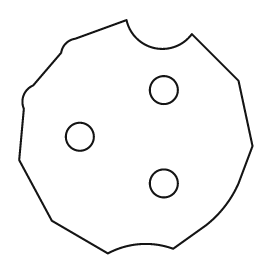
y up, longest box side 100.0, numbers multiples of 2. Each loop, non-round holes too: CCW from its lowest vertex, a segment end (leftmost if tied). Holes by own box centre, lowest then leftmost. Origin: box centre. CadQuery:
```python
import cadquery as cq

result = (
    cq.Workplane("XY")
    .moveTo(-12.0, -50.0)
    .threePointArc((2.0, -46.0), (16.0, -48.0))
    .lineTo(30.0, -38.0)
    .threePointArc((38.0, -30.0), (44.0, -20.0))
    .lineTo(50.0, -4.0)
    .lineTo(44.0, 24.0)
    .lineTo(24.0, 44.0)
    .threePointArc((8.0, 38.0), (-4.0, 50.0))
    .lineTo(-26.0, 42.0)
    .threePointArc((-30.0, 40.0), (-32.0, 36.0))
    .lineTo(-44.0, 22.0)
    .threePointArc((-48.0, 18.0), (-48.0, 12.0))
    .lineTo(-50.0, -10.0)
    .lineTo(-36.0, -36.0)
    .close()
    .moveTo(12.0, -20.0)
    .circle(6.0)
    .moveTo(-24.0, 0.0)
    .circle(6.0)
    .moveTo(12.0, 20.0)
    .circle(6.0)
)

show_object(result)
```